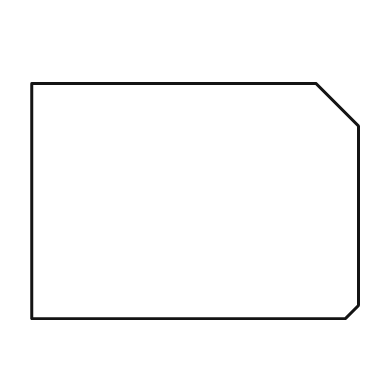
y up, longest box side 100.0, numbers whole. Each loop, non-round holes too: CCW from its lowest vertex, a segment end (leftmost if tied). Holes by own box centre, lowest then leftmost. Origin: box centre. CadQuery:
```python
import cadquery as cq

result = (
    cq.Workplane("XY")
    .moveTo(-50.0, -36.0)
    .lineTo(46.0, -36.0)
    .lineTo(50.0, -32.0)
    .lineTo(50.0, 23.0)
    .lineTo(37.0, 36.0)
    .lineTo(-50.0, 36.0)
    .close()
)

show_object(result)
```